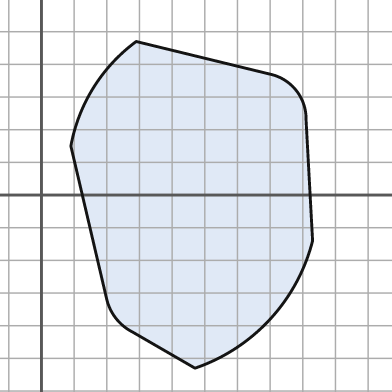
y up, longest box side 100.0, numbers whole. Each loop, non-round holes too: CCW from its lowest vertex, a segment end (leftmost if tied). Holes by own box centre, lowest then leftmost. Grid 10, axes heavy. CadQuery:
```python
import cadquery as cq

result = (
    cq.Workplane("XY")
    .moveTo(47.0, -53.0)
    .threePointArc((70.0, -38.0), (83.0, -14.0))
    .lineTo(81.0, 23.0)
    .threePointArc((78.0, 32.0), (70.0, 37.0))
    .lineTo(29.0, 47.0)
    .threePointArc((16.0, 33.0), (9.0, 15.0))
    .lineTo(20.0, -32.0)
    .threePointArc((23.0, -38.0), (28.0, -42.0))
    .close()
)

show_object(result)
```